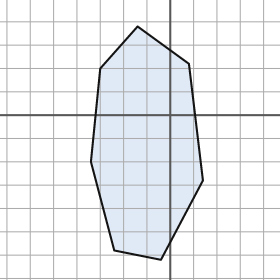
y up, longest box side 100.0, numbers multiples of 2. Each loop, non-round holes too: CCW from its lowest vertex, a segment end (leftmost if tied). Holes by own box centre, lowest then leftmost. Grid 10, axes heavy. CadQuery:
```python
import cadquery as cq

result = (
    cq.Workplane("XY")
    .moveTo(-4.0, -62.0)
    .lineTo(14.0, -28.0)
    .lineTo(8.0, 22.0)
    .lineTo(-14.0, 38.0)
    .lineTo(-30.0, 20.0)
    .lineTo(-34.0, -20.0)
    .lineTo(-24.0, -58.0)
    .close()
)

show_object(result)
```